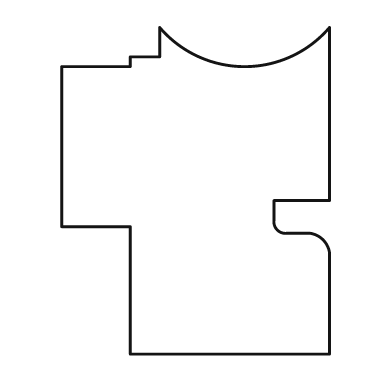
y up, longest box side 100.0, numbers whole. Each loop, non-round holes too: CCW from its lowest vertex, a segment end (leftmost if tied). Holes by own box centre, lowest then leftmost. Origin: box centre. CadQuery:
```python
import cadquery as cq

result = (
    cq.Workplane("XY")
    .moveTo(-20.0, -50.0)
    .lineTo(41.0, -50.0)
    .lineTo(41.0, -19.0)
    .threePointArc((39.0, -15.0), (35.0, -13.0))
    .lineTo(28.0, -13.0)
    .threePointArc((25.0, -12.0), (24.0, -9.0))
    .lineTo(24.0, -3.0)
    .lineTo(41.0, -3.0)
    .lineTo(41.0, 50.0)
    .threePointArc((15.0, 38.0), (-11.0, 50.0))
    .lineTo(-11.0, 41.0)
    .lineTo(-20.0, 41.0)
    .lineTo(-20.0, 38.0)
    .lineTo(-41.0, 38.0)
    .lineTo(-41.0, -11.0)
    .lineTo(-20.0, -11.0)
    .close()
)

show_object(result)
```